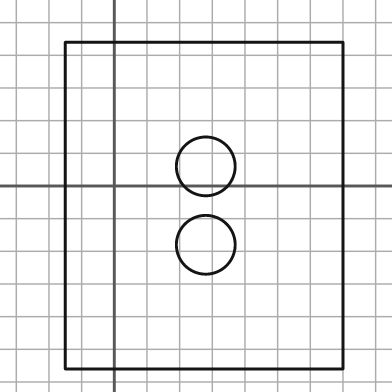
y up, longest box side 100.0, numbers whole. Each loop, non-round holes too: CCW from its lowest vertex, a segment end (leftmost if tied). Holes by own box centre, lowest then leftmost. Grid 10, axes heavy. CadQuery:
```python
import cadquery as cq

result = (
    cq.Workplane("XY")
    .moveTo(-15.0, -56.0)
    .lineTo(70.0, -56.0)
    .lineTo(70.0, 44.0)
    .lineTo(-15.0, 44.0)
    .close()
    .moveTo(28.0, -18.0)
    .circle(9.0)
    .moveTo(28.0, 6.0)
    .circle(9.0)
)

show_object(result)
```